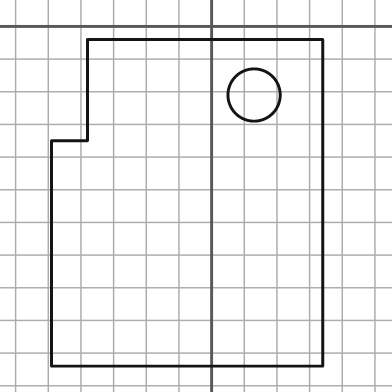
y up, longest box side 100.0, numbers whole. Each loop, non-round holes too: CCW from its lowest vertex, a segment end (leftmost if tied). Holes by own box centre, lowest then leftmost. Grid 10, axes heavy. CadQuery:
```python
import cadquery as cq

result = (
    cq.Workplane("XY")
    .moveTo(-49.0, -104.0)
    .lineTo(34.0, -104.0)
    .lineTo(34.0, -4.0)
    .lineTo(-38.0, -4.0)
    .lineTo(-38.0, -35.0)
    .lineTo(-49.0, -35.0)
    .close()
    .moveTo(13.0, -21.0)
    .circle(8.0)
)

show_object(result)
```